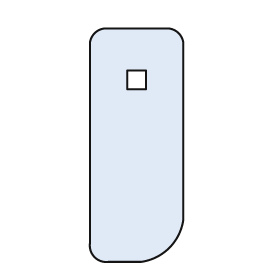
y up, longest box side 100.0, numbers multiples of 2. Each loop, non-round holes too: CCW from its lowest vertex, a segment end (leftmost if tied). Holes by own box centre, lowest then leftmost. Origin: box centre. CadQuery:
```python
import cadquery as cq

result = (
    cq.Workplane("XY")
    .moveTo(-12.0, -50.0)
    .lineTo(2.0, -50.0)
    .threePointArc((14.0, -44.0), (20.0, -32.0))
    .lineTo(20.0, 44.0)
    .threePointArc((18.0, 48.0), (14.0, 50.0))
    .lineTo(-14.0, 50.0)
    .threePointArc((-18.0, 48.0), (-20.0, 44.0))
    .lineTo(-20.0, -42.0)
    .threePointArc((-18.0, -48.0), (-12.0, -50.0))
    .close()
    .moveTo(-4.0, 24.0)
    .lineTo(4.0, 24.0)
    .lineTo(4.0, 32.0)
    .lineTo(-4.0, 32.0)
    .close()
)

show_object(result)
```